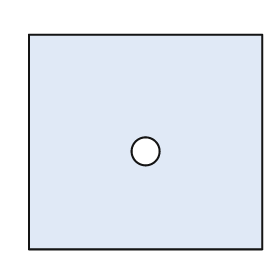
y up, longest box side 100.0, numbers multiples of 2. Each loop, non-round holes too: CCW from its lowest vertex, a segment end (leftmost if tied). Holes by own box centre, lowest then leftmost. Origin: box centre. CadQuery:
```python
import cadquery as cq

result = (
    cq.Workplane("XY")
    .moveTo(-50.0, -46.0)
    .lineTo(50.0, -46.0)
    .lineTo(50.0, 46.0)
    .lineTo(-50.0, 46.0)
    .close()
    .moveTo(0.0, -4.0)
    .circle(6.0)
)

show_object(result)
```